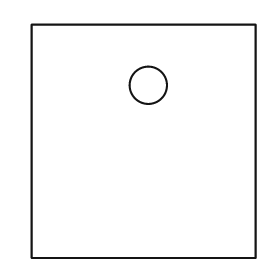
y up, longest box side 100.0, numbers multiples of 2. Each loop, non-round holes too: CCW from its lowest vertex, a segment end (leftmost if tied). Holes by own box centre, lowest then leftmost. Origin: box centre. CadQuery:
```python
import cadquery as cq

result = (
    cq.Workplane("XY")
    .moveTo(-48.0, -50.0)
    .lineTo(48.0, -50.0)
    .lineTo(48.0, 50.0)
    .lineTo(-48.0, 50.0)
    .close()
    .moveTo(2.0, 24.0)
    .circle(8.0)
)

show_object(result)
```